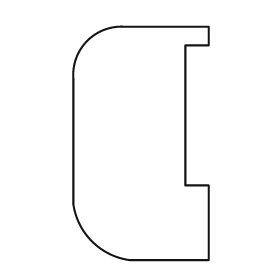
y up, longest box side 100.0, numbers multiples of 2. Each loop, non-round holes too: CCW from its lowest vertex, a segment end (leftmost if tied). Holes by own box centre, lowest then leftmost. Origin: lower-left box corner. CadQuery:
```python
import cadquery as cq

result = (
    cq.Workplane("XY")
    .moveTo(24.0, 0.0)
    .lineTo(58.0, 0.0)
    .lineTo(58.0, 32.0)
    .lineTo(48.0, 32.0)
    .lineTo(48.0, 92.0)
    .lineTo(58.0, 92.0)
    .lineTo(58.0, 100.0)
    .lineTo(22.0, 100.0)
    .threePointArc((6.0, 94.0), (0.0, 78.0))
    .lineTo(0.0, 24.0)
    .threePointArc((8.0, 8.0), (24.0, 0.0))
    .close()
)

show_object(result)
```